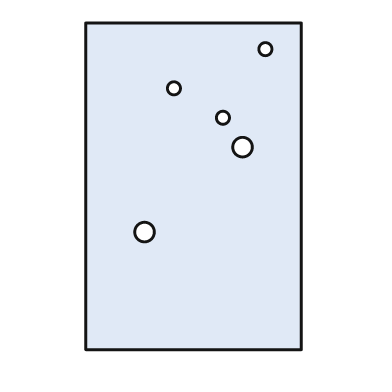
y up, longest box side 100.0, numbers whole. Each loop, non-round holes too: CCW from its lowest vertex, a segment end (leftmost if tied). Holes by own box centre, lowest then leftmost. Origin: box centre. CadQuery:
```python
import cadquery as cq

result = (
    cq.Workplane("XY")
    .moveTo(-33.0, -50.0)
    .lineTo(33.0, -50.0)
    .lineTo(33.0, 50.0)
    .lineTo(-33.0, 50.0)
    .close()
    .moveTo(-15.0, -14.0)
    .circle(3.0)
    .moveTo(15.0, 12.0)
    .circle(3.0)
    .moveTo(9.0, 21.0)
    .circle(2.0)
    .moveTo(-6.0, 30.0)
    .circle(2.0)
    .moveTo(22.0, 42.0)
    .circle(2.0)
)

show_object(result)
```